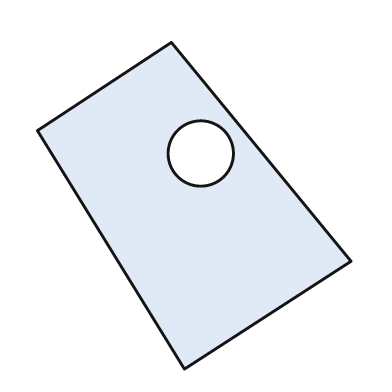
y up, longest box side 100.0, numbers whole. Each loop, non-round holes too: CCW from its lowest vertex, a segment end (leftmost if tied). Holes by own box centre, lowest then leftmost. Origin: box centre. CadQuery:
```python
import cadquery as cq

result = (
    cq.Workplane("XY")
    .moveTo(-3.0, -50.0)
    .lineTo(48.0, -17.0)
    .lineTo(-7.0, 50.0)
    .lineTo(-48.0, 23.0)
    .close()
    .moveTo(2.0, 16.0)
    .circle(10.0)
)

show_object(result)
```